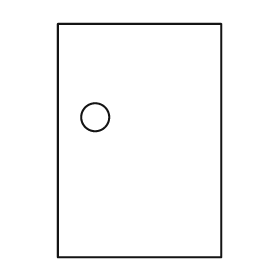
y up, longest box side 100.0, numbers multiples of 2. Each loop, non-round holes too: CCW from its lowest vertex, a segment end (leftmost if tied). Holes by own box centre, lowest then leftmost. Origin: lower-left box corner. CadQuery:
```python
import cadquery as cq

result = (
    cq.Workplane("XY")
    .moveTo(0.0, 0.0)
    .lineTo(70.0, 0.0)
    .lineTo(70.0, 100.0)
    .lineTo(0.0, 100.0)
    .close()
    .moveTo(16.0, 60.0)
    .circle(6.0)
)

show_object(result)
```